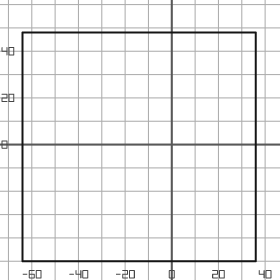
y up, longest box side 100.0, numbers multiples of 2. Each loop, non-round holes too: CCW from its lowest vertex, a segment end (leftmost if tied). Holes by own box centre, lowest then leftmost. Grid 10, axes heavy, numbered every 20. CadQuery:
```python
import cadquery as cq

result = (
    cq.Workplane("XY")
    .moveTo(-64.0, -50.0)
    .lineTo(36.0, -50.0)
    .lineTo(36.0, 48.0)
    .lineTo(-64.0, 48.0)
    .close()
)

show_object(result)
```